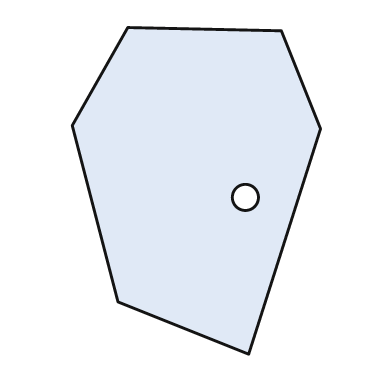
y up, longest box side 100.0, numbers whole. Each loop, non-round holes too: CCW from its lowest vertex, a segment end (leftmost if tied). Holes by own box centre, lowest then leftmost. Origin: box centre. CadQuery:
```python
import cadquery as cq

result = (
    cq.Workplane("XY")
    .moveTo(16.0, -50.0)
    .lineTo(38.0, 19.0)
    .lineTo(26.0, 49.0)
    .lineTo(-21.0, 50.0)
    .lineTo(-38.0, 20.0)
    .lineTo(-24.0, -34.0)
    .close()
    .moveTo(15.0, -2.0)
    .circle(4.0)
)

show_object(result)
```